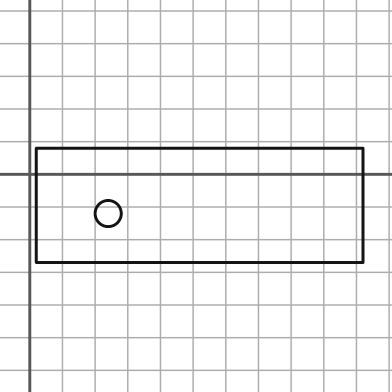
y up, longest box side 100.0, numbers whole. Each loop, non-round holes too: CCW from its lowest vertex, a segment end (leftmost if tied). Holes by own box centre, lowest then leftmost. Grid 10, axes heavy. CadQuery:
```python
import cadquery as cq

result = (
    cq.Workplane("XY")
    .moveTo(2.0, -27.0)
    .lineTo(102.0, -27.0)
    .lineTo(102.0, 8.0)
    .lineTo(2.0, 8.0)
    .close()
    .moveTo(24.0, -12.0)
    .circle(4.0)
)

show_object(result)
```